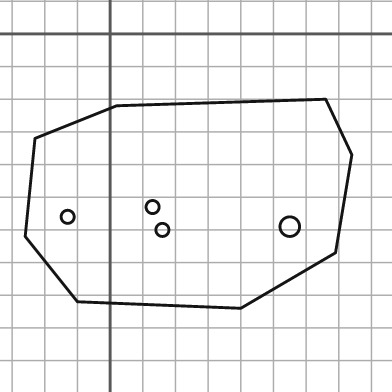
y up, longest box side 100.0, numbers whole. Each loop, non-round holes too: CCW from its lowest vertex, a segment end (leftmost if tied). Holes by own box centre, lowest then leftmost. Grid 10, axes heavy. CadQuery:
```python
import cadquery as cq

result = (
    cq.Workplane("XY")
    .moveTo(40.0, -84.0)
    .lineTo(69.0, -67.0)
    .lineTo(74.0, -37.0)
    .lineTo(66.0, -20.0)
    .lineTo(2.0, -22.0)
    .lineTo(-23.0, -32.0)
    .lineTo(-26.0, -62.0)
    .lineTo(-10.0, -82.0)
    .close()
    .moveTo(16.0, -60.0)
    .circle(2.0)
    .moveTo(55.0, -59.0)
    .circle(3.0)
    .moveTo(-13.0, -56.0)
    .circle(2.0)
    .moveTo(13.0, -53.0)
    .circle(2.0)
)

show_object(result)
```